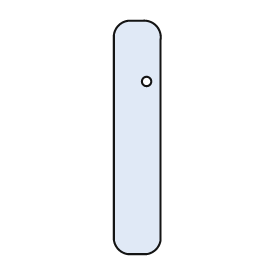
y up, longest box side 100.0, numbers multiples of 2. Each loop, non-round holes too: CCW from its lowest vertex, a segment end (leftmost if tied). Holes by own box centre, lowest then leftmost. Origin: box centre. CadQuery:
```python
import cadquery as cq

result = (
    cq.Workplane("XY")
    .moveTo(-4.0, -50.0)
    .lineTo(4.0, -50.0)
    .threePointArc((8.0, -48.0), (10.0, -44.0))
    .lineTo(10.0, 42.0)
    .threePointArc((8.0, 48.0), (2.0, 50.0))
    .lineTo(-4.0, 50.0)
    .threePointArc((-8.0, 48.0), (-10.0, 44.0))
    .lineTo(-10.0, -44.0)
    .threePointArc((-8.0, -48.0), (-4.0, -50.0))
    .close()
    .moveTo(4.0, 24.0)
    .circle(2.0)
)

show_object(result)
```